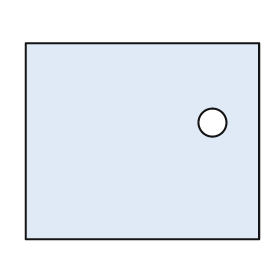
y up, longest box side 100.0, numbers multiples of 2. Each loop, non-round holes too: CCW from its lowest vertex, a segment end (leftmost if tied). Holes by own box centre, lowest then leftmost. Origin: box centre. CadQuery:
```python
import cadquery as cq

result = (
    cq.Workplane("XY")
    .moveTo(-50.0, -42.0)
    .lineTo(50.0, -42.0)
    .lineTo(50.0, 42.0)
    .lineTo(-50.0, 42.0)
    .close()
    .moveTo(30.0, 8.0)
    .circle(6.0)
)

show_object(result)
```